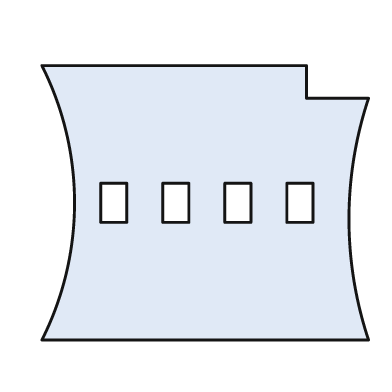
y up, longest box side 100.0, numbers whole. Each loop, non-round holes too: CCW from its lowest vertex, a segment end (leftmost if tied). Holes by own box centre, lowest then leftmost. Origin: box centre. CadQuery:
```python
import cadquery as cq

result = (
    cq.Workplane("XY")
    .moveTo(-50.0, -42.0)
    .lineTo(50.0, -42.0)
    .threePointArc((44.0, -5.0), (50.0, 32.0))
    .lineTo(31.0, 32.0)
    .lineTo(31.0, 42.0)
    .lineTo(-50.0, 42.0)
    .threePointArc((-40.0, 0.0), (-50.0, -42.0))
    .close()
    .moveTo(-32.0, -6.0)
    .lineTo(-24.0, -6.0)
    .lineTo(-24.0, 6.0)
    .lineTo(-32.0, 6.0)
    .close()
    .moveTo(-13.0, -6.0)
    .lineTo(-5.0, -6.0)
    .lineTo(-5.0, 6.0)
    .lineTo(-13.0, 6.0)
    .close()
    .moveTo(6.0, -6.0)
    .lineTo(14.0, -6.0)
    .lineTo(14.0, 6.0)
    .lineTo(6.0, 6.0)
    .close()
    .moveTo(25.0, -6.0)
    .lineTo(33.0, -6.0)
    .lineTo(33.0, 6.0)
    .lineTo(25.0, 6.0)
    .close()
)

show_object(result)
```